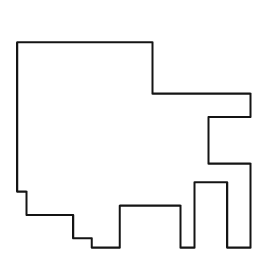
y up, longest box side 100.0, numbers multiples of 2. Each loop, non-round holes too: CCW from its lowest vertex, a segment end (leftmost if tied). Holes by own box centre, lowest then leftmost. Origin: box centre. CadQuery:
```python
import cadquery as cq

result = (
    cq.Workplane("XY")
    .moveTo(-18.0, -44.0)
    .lineTo(-6.0, -44.0)
    .lineTo(-6.0, -26.0)
    .lineTo(20.0, -26.0)
    .lineTo(20.0, -44.0)
    .lineTo(26.0, -44.0)
    .lineTo(26.0, -16.0)
    .lineTo(40.0, -16.0)
    .lineTo(40.0, -44.0)
    .lineTo(50.0, -44.0)
    .lineTo(50.0, -8.0)
    .lineTo(32.0, -8.0)
    .lineTo(32.0, 12.0)
    .lineTo(50.0, 12.0)
    .lineTo(50.0, 22.0)
    .lineTo(8.0, 22.0)
    .lineTo(8.0, 44.0)
    .lineTo(-50.0, 44.0)
    .lineTo(-50.0, -20.0)
    .lineTo(-46.0, -20.0)
    .lineTo(-46.0, -30.0)
    .lineTo(-26.0, -30.0)
    .lineTo(-26.0, -40.0)
    .lineTo(-18.0, -40.0)
    .close()
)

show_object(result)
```